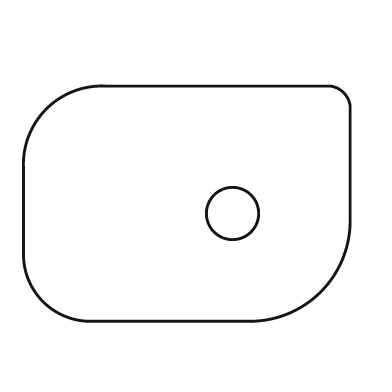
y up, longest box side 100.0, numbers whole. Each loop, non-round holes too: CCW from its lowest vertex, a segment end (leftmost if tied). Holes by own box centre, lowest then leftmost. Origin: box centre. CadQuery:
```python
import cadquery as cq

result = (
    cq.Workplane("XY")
    .moveTo(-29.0, -36.0)
    .lineTo(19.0, -36.0)
    .threePointArc((41.0, -27.0), (50.0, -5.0))
    .lineTo(50.0, 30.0)
    .threePointArc((48.0, 34.0), (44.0, 36.0))
    .lineTo(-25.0, 36.0)
    .threePointArc((-43.0, 29.0), (-50.0, 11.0))
    .lineTo(-50.0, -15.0)
    .threePointArc((-44.0, -30.0), (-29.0, -36.0))
    .close()
    .moveTo(14.0, -3.0)
    .circle(8.0)
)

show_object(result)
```